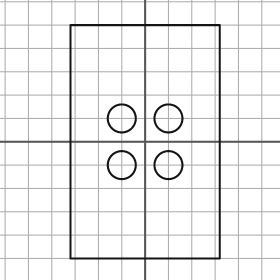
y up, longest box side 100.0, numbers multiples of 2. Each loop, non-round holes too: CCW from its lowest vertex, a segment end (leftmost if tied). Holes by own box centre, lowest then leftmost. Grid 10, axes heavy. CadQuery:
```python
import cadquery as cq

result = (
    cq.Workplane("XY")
    .moveTo(-32.0, -50.0)
    .lineTo(32.0, -50.0)
    .lineTo(32.0, 50.0)
    .lineTo(-32.0, 50.0)
    .close()
    .moveTo(-10.0, -10.0)
    .circle(6.0)
    .moveTo(10.0, -10.0)
    .circle(6.0)
    .moveTo(-10.0, 10.0)
    .circle(6.0)
    .moveTo(10.0, 10.0)
    .circle(6.0)
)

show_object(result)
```